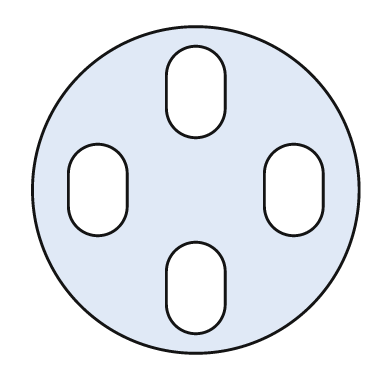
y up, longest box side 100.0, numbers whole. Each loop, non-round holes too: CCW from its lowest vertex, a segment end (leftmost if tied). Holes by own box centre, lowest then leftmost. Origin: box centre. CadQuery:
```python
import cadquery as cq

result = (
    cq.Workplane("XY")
    .moveTo(0.0, 0.0)
    .circle(50.0)
    .moveTo(-9.0, -35.0)
    .threePointArc((0.0, -44.0), (9.0, -35.0))
    .lineTo(9.0, -25.0)
    .threePointArc((0.0, -16.0), (-9.0, -25.0))
    .close()
    .moveTo(-39.0, -5.0)
    .threePointArc((-30.0, -14.0), (-21.0, -5.0))
    .lineTo(-21.0, 5.0)
    .threePointArc((-30.0, 14.0), (-39.0, 5.0))
    .close()
    .moveTo(21.0, -5.0)
    .threePointArc((30.0, -14.0), (39.0, -5.0))
    .lineTo(39.0, 5.0)
    .threePointArc((30.0, 14.0), (21.0, 5.0))
    .close()
    .moveTo(-9.0, 25.0)
    .threePointArc((0.0, 16.0), (9.0, 25.0))
    .lineTo(9.0, 35.0)
    .threePointArc((0.0, 44.0), (-9.0, 35.0))
    .close()
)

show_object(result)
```